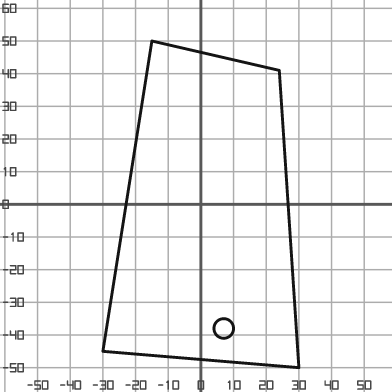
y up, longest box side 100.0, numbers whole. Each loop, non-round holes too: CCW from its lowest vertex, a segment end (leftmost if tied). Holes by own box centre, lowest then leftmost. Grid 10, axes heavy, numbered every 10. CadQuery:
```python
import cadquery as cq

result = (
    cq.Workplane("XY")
    .moveTo(30.0, -50.0)
    .lineTo(24.0, 41.0)
    .lineTo(-15.0, 50.0)
    .lineTo(-30.0, -45.0)
    .close()
    .moveTo(7.0, -38.0)
    .circle(3.0)
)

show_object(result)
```